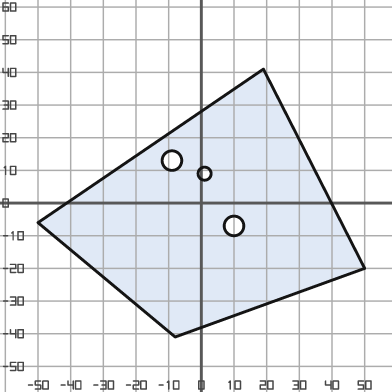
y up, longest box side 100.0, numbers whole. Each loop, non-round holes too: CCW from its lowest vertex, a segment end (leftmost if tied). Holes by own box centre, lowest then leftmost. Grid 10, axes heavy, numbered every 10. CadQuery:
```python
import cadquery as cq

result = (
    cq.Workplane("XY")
    .moveTo(-8.0, -41.0)
    .lineTo(50.0, -20.0)
    .lineTo(19.0, 41.0)
    .lineTo(-50.0, -6.0)
    .close()
    .moveTo(10.0, -7.0)
    .circle(3.0)
    .moveTo(1.0, 9.0)
    .circle(2.0)
    .moveTo(-9.0, 13.0)
    .circle(3.0)
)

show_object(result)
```